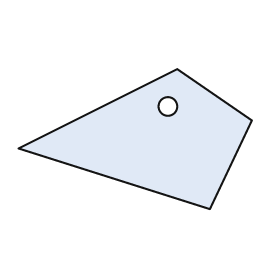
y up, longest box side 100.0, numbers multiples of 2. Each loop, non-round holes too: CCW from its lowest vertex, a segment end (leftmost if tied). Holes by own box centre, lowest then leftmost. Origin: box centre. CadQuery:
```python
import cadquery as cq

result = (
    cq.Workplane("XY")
    .moveTo(32.0, -30.0)
    .lineTo(50.0, 8.0)
    .lineTo(18.0, 30.0)
    .lineTo(-50.0, -4.0)
    .close()
    .moveTo(14.0, 14.0)
    .circle(4.0)
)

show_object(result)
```